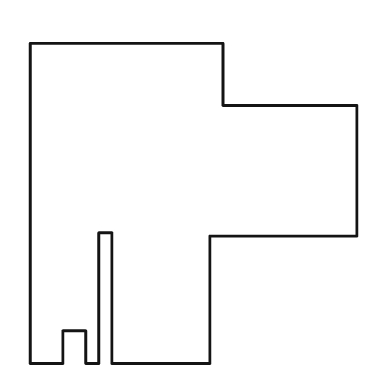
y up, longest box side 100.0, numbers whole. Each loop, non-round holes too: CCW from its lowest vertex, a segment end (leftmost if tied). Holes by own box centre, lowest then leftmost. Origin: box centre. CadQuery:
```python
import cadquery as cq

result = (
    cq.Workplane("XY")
    .moveTo(-50.0, -49.0)
    .lineTo(-40.0, -49.0)
    .lineTo(-40.0, -39.0)
    .lineTo(-33.0, -39.0)
    .lineTo(-33.0, -49.0)
    .lineTo(-29.0, -49.0)
    .lineTo(-29.0, -9.0)
    .lineTo(-25.0, -9.0)
    .lineTo(-25.0, -49.0)
    .lineTo(5.0, -49.0)
    .lineTo(5.0, -10.0)
    .lineTo(50.0, -10.0)
    .lineTo(50.0, 30.0)
    .lineTo(9.0, 30.0)
    .lineTo(9.0, 49.0)
    .lineTo(-50.0, 49.0)
    .close()
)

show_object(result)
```